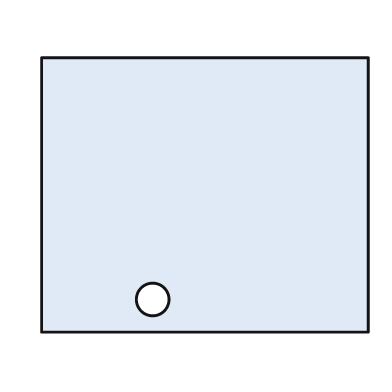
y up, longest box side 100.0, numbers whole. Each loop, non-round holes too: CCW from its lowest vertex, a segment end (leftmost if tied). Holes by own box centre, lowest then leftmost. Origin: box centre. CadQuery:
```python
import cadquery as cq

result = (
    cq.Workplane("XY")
    .moveTo(-50.0, -42.0)
    .lineTo(50.0, -42.0)
    .lineTo(50.0, 42.0)
    .lineTo(-50.0, 42.0)
    .close()
    .moveTo(-16.0, -32.0)
    .circle(5.0)
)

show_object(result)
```